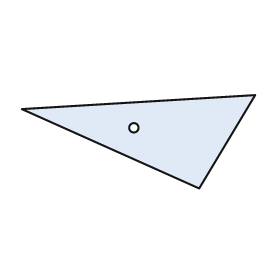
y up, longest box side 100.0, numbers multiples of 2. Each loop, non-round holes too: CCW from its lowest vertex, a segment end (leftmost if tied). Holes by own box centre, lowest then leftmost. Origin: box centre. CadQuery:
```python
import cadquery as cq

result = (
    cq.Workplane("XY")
    .moveTo(26.0, -20.0)
    .lineTo(50.0, 20.0)
    .lineTo(-50.0, 14.0)
    .close()
    .moveTo(-2.0, 6.0)
    .circle(2.0)
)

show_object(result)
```